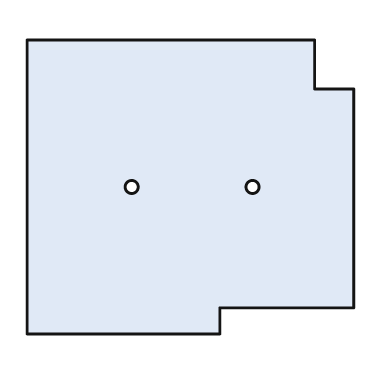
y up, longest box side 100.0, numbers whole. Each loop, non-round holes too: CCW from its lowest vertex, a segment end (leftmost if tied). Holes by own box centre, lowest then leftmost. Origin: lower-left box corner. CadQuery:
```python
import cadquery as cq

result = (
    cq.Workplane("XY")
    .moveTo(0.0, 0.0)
    .lineTo(59.0, 0.0)
    .lineTo(59.0, 8.0)
    .lineTo(100.0, 8.0)
    .lineTo(100.0, 75.0)
    .lineTo(88.0, 75.0)
    .lineTo(88.0, 90.0)
    .lineTo(0.0, 90.0)
    .close()
    .moveTo(32.0, 45.0)
    .circle(2.0)
    .moveTo(69.0, 45.0)
    .circle(2.0)
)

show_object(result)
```